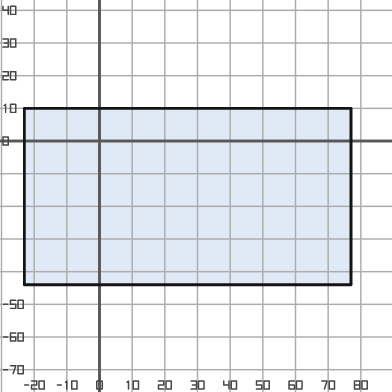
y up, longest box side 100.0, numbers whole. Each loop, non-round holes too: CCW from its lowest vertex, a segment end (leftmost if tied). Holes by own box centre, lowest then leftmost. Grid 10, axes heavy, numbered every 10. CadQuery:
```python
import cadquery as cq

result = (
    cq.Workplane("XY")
    .moveTo(-23.0, -44.0)
    .lineTo(77.0, -44.0)
    .lineTo(77.0, 10.0)
    .lineTo(-23.0, 10.0)
    .close()
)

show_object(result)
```